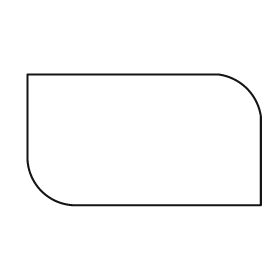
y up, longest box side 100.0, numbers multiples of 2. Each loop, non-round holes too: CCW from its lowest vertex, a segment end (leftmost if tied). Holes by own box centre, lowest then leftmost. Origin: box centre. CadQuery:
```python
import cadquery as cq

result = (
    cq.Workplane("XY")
    .moveTo(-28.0, -28.0)
    .lineTo(50.0, -28.0)
    .lineTo(50.0, 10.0)
    .threePointArc((44.0, 22.0), (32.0, 28.0))
    .lineTo(-50.0, 28.0)
    .lineTo(-50.0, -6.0)
    .threePointArc((-44.0, -22.0), (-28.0, -28.0))
    .close()
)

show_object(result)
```